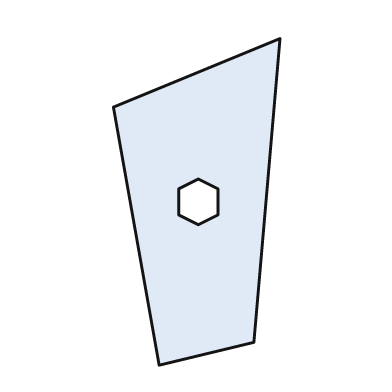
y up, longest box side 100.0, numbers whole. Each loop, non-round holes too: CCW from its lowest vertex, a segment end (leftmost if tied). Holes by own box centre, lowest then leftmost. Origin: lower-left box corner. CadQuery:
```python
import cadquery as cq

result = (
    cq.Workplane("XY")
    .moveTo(14.0, 0.0)
    .lineTo(43.0, 7.0)
    .lineTo(51.0, 100.0)
    .lineTo(0.0, 79.0)
    .close()
    .moveTo(26.0, 43.0)
    .lineTo(32.0, 46.0)
    .lineTo(32.0, 54.0)
    .lineTo(26.0, 57.0)
    .lineTo(20.0, 54.0)
    .lineTo(20.0, 46.0)
    .close()
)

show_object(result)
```